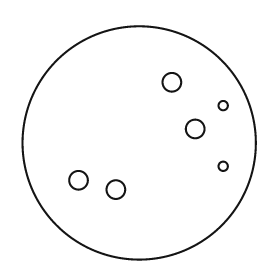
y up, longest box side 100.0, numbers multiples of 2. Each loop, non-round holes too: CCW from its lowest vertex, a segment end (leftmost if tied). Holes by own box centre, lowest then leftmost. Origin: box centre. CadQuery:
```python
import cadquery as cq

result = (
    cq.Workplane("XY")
    .moveTo(0.0, 0.0)
    .circle(50.0)
    .moveTo(-10.0, -20.0)
    .circle(4.0)
    .moveTo(-26.0, -16.0)
    .circle(4.0)
    .moveTo(36.0, -10.0)
    .circle(2.0)
    .moveTo(24.0, 6.0)
    .circle(4.0)
    .moveTo(36.0, 16.0)
    .circle(2.0)
    .moveTo(14.0, 26.0)
    .circle(4.0)
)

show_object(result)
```